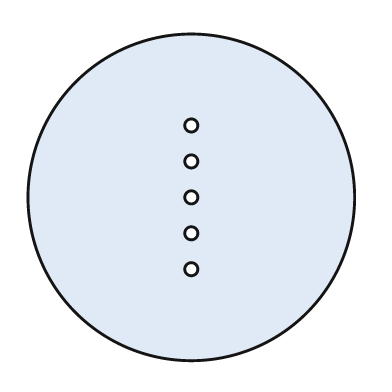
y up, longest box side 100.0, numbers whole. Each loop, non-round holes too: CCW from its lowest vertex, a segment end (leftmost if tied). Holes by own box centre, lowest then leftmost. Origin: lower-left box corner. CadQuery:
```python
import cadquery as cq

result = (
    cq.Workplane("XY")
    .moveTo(50.0, 50.0)
    .circle(50.0)
    .moveTo(50.0, 28.0)
    .circle(2.0)
    .moveTo(50.0, 39.0)
    .circle(2.0)
    .moveTo(50.0, 50.0)
    .circle(2.0)
    .moveTo(50.0, 61.0)
    .circle(2.0)
    .moveTo(50.0, 72.0)
    .circle(2.0)
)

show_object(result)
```